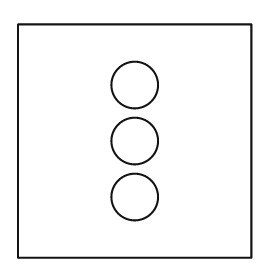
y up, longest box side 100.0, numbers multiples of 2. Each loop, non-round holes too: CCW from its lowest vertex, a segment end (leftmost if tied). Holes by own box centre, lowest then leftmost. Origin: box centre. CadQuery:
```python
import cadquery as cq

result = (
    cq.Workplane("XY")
    .moveTo(-50.0, -50.0)
    .lineTo(50.0, -50.0)
    .lineTo(50.0, 50.0)
    .lineTo(-50.0, 50.0)
    .close()
    .moveTo(0.0, -24.0)
    .circle(10.0)
    .moveTo(0.0, 0.0)
    .circle(10.0)
    .moveTo(0.0, 24.0)
    .circle(10.0)
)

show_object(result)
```